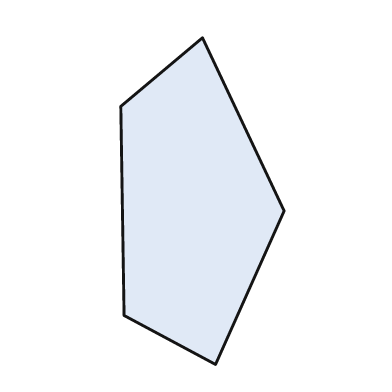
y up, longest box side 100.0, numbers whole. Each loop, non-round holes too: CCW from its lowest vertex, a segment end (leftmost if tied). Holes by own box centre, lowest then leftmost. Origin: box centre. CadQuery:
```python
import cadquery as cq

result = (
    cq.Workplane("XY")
    .moveTo(4.0, -50.0)
    .lineTo(25.0, -3.0)
    .lineTo(0.0, 50.0)
    .lineTo(-25.0, 29.0)
    .lineTo(-24.0, -35.0)
    .close()
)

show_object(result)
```